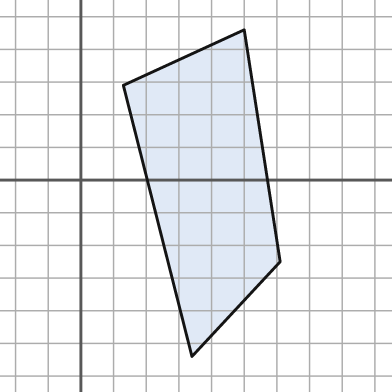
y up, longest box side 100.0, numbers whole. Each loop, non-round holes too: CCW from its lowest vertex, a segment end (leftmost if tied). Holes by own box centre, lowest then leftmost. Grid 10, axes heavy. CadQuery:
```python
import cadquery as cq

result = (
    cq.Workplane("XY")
    .moveTo(34.0, -54.0)
    .lineTo(61.0, -25.0)
    .lineTo(50.0, 46.0)
    .lineTo(13.0, 29.0)
    .close()
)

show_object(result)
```